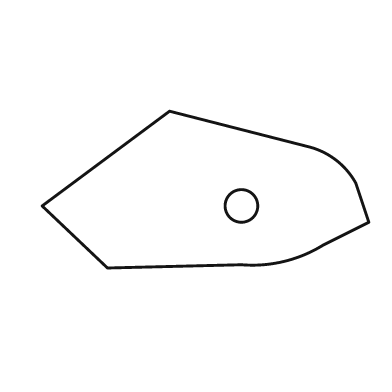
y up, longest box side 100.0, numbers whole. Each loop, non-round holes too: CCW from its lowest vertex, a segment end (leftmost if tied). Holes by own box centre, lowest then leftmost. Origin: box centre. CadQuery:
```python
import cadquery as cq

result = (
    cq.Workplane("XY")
    .moveTo(-30.0, -24.0)
    .lineTo(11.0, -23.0)
    .threePointArc((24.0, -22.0), (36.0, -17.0))
    .lineTo(50.0, -10.0)
    .lineTo(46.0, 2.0)
    .threePointArc((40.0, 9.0), (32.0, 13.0))
    .lineTo(-11.0, 24.0)
    .lineTo(-50.0, -5.0)
    .close()
    .moveTo(11.0, -5.0)
    .circle(5.0)
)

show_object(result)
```